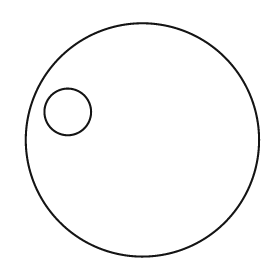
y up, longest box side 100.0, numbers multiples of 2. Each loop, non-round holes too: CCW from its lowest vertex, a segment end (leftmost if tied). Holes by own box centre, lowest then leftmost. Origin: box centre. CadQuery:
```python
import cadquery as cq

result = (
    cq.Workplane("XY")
    .moveTo(0.0, 0.0)
    .circle(50.0)
    .moveTo(-32.0, 12.0)
    .circle(10.0)
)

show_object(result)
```